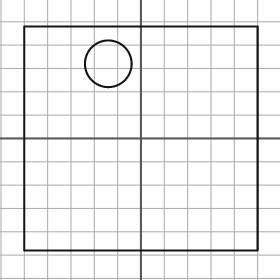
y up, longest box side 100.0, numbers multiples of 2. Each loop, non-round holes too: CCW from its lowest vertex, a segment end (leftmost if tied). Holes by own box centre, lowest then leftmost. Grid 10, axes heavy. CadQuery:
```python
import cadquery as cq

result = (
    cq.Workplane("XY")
    .moveTo(-50.0, -48.0)
    .lineTo(50.0, -48.0)
    .lineTo(50.0, 48.0)
    .lineTo(-50.0, 48.0)
    .close()
    .moveTo(-14.0, 32.0)
    .circle(10.0)
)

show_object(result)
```